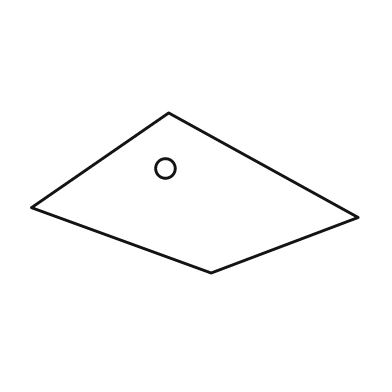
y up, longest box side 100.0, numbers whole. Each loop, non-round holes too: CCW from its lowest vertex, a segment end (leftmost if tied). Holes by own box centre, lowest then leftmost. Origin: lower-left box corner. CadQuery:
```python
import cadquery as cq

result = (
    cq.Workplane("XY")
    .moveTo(55.0, 0.0)
    .lineTo(100.0, 17.0)
    .lineTo(42.0, 49.0)
    .lineTo(0.0, 20.0)
    .close()
    .moveTo(41.0, 32.0)
    .circle(3.0)
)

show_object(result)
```